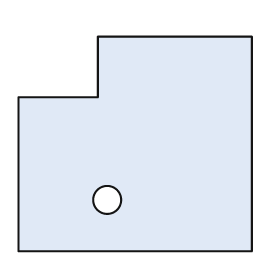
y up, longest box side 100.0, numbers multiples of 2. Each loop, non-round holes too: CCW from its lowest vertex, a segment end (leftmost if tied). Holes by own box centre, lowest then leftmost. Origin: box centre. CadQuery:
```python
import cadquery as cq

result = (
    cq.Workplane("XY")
    .moveTo(-50.0, -46.0)
    .lineTo(50.0, -46.0)
    .lineTo(50.0, 46.0)
    .lineTo(-16.0, 46.0)
    .lineTo(-16.0, 20.0)
    .lineTo(-50.0, 20.0)
    .close()
    .moveTo(-12.0, -24.0)
    .circle(6.0)
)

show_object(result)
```